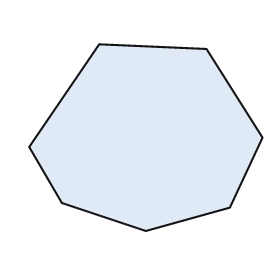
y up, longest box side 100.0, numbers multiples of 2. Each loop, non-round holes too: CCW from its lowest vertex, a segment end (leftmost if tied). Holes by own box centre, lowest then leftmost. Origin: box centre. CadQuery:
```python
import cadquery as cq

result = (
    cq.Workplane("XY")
    .moveTo(0.0, -40.0)
    .lineTo(36.0, -30.0)
    .lineTo(50.0, 0.0)
    .lineTo(26.0, 38.0)
    .lineTo(-20.0, 40.0)
    .lineTo(-50.0, -4.0)
    .lineTo(-36.0, -28.0)
    .close()
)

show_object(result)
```